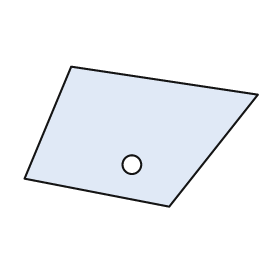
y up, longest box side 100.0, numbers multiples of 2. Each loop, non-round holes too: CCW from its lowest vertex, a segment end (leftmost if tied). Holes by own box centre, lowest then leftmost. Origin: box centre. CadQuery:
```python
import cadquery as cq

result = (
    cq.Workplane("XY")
    .moveTo(12.0, -30.0)
    .lineTo(50.0, 18.0)
    .lineTo(-30.0, 30.0)
    .lineTo(-50.0, -18.0)
    .close()
    .moveTo(-4.0, -12.0)
    .circle(4.0)
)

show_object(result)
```